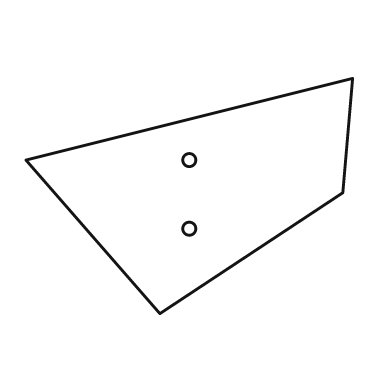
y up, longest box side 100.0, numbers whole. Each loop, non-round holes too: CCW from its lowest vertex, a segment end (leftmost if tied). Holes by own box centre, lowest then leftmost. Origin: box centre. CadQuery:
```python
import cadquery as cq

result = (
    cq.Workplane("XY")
    .moveTo(-9.0, -36.0)
    .lineTo(47.0, 1.0)
    .lineTo(50.0, 36.0)
    .lineTo(-50.0, 11.0)
    .close()
    .moveTo(0.0, -10.0)
    .circle(2.0)
    .moveTo(0.0, 11.0)
    .circle(2.0)
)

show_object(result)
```